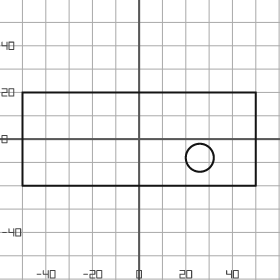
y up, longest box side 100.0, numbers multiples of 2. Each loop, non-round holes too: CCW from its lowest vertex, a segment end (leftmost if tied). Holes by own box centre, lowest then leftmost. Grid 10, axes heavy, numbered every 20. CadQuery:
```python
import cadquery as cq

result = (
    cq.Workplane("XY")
    .moveTo(-50.0, -20.0)
    .lineTo(50.0, -20.0)
    .lineTo(50.0, 20.0)
    .lineTo(-50.0, 20.0)
    .close()
    .moveTo(26.0, -8.0)
    .circle(6.0)
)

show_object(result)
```